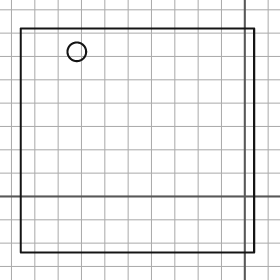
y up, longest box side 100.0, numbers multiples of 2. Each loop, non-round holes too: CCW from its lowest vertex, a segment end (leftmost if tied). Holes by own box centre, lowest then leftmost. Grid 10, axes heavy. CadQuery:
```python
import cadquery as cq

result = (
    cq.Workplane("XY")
    .moveTo(-96.0, -24.0)
    .lineTo(4.0, -24.0)
    .lineTo(4.0, 72.0)
    .lineTo(-96.0, 72.0)
    .close()
    .moveTo(-72.0, 62.0)
    .circle(4.0)
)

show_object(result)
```